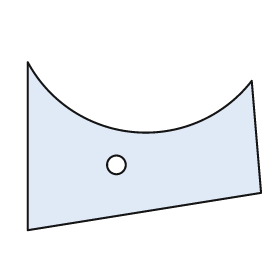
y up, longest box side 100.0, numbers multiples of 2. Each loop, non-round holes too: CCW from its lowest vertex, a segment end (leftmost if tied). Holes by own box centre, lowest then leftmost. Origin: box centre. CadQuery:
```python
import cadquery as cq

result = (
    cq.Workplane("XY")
    .moveTo(-50.0, -36.0)
    .lineTo(50.0, -20.0)
    .lineTo(46.0, 28.0)
    .threePointArc((-4.0, 6.0), (-50.0, 36.0))
    .close()
    .moveTo(-12.0, -8.0)
    .circle(4.0)
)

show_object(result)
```